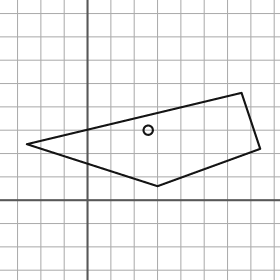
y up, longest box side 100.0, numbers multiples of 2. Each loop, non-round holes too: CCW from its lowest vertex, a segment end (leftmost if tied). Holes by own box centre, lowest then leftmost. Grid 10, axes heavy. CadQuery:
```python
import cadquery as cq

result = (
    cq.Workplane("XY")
    .moveTo(30.0, 6.0)
    .lineTo(74.0, 22.0)
    .lineTo(66.0, 46.0)
    .lineTo(-26.0, 24.0)
    .close()
    .moveTo(26.0, 30.0)
    .circle(2.0)
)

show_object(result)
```